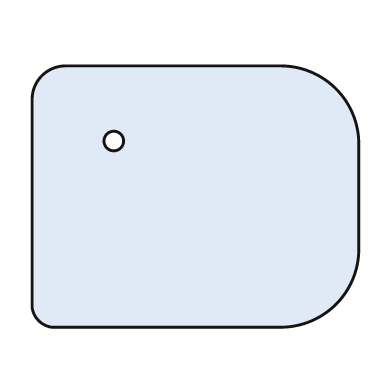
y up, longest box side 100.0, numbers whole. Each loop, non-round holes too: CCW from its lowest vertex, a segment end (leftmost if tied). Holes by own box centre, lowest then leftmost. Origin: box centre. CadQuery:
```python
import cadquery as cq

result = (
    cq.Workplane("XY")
    .moveTo(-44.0, -40.0)
    .lineTo(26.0, -40.0)
    .threePointArc((43.0, -33.0), (50.0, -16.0))
    .lineTo(50.0, 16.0)
    .threePointArc((43.0, 33.0), (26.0, 40.0))
    .lineTo(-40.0, 40.0)
    .threePointArc((-47.0, 37.0), (-50.0, 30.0))
    .lineTo(-50.0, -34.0)
    .threePointArc((-48.0, -38.0), (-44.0, -40.0))
    .close()
    .moveTo(-25.0, 17.0)
    .circle(3.0)
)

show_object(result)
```